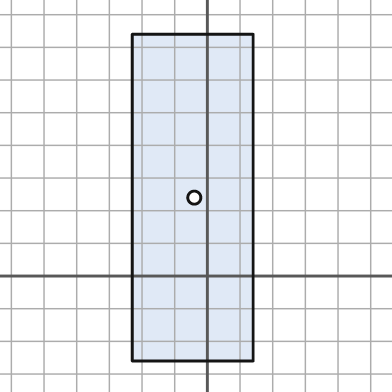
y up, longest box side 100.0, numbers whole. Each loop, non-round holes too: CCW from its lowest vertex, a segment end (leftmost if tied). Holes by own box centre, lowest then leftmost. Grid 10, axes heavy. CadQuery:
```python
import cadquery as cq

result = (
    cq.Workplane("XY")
    .moveTo(-23.0, -26.0)
    .lineTo(14.0, -26.0)
    .lineTo(14.0, 74.0)
    .lineTo(-23.0, 74.0)
    .close()
    .moveTo(-4.0, 24.0)
    .circle(2.0)
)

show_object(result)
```